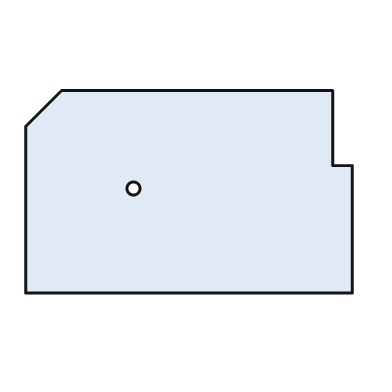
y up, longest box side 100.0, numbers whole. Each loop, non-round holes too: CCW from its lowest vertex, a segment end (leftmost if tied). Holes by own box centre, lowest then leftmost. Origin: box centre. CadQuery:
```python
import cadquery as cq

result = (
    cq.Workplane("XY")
    .moveTo(-50.0, -31.0)
    .lineTo(50.0, -31.0)
    .lineTo(50.0, 8.0)
    .lineTo(44.0, 8.0)
    .lineTo(44.0, 31.0)
    .lineTo(-39.0, 31.0)
    .lineTo(-50.0, 20.0)
    .close()
    .moveTo(-17.0, 1.0)
    .circle(2.0)
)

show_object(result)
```